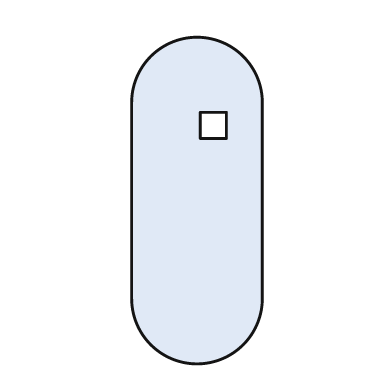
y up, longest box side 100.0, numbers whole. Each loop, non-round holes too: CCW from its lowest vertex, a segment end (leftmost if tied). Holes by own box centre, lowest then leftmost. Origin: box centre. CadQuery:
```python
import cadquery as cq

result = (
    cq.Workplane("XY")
    .moveTo(-20.0, -30.0)
    .threePointArc((0.0, -50.0), (20.0, -30.0))
    .lineTo(20.0, 30.0)
    .threePointArc((0.0, 50.0), (-20.0, 30.0))
    .close()
    .moveTo(1.0, 19.0)
    .lineTo(9.0, 19.0)
    .lineTo(9.0, 27.0)
    .lineTo(1.0, 27.0)
    .close()
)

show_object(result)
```